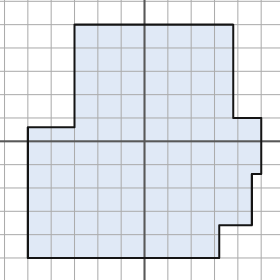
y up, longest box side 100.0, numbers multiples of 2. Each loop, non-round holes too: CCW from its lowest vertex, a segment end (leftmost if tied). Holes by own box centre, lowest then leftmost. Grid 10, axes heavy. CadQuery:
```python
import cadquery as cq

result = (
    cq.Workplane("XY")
    .moveTo(-50.0, -50.0)
    .lineTo(32.0, -50.0)
    .lineTo(32.0, -36.0)
    .lineTo(46.0, -36.0)
    .lineTo(46.0, -14.0)
    .lineTo(50.0, -14.0)
    .lineTo(50.0, 10.0)
    .lineTo(38.0, 10.0)
    .lineTo(38.0, 50.0)
    .lineTo(-30.0, 50.0)
    .lineTo(-30.0, 6.0)
    .lineTo(-50.0, 6.0)
    .close()
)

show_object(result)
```